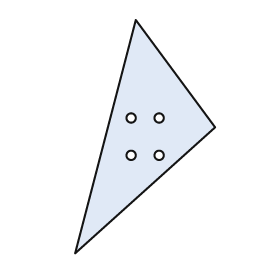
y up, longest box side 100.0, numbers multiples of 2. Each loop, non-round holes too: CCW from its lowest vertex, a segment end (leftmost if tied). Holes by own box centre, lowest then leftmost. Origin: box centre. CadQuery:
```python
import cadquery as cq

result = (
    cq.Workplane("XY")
    .moveTo(-30.0, -50.0)
    .lineTo(30.0, 4.0)
    .lineTo(-4.0, 50.0)
    .close()
    .moveTo(-6.0, -8.0)
    .circle(2.0)
    .moveTo(6.0, -8.0)
    .circle(2.0)
    .moveTo(-6.0, 8.0)
    .circle(2.0)
    .moveTo(6.0, 8.0)
    .circle(2.0)
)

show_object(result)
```